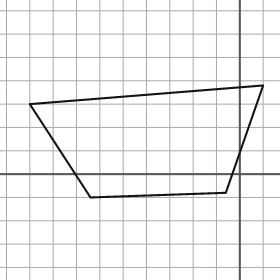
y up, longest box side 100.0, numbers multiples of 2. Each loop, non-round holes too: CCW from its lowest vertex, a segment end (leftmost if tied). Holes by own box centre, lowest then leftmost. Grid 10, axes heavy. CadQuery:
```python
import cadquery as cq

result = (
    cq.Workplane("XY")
    .moveTo(-64.0, -10.0)
    .lineTo(-6.0, -8.0)
    .lineTo(10.0, 38.0)
    .lineTo(-90.0, 30.0)
    .close()
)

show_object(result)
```